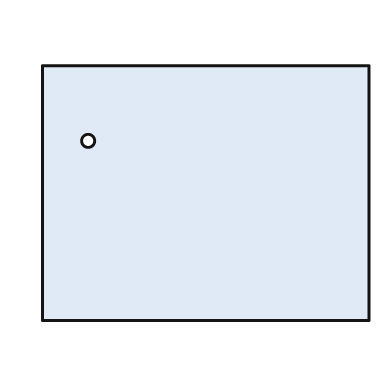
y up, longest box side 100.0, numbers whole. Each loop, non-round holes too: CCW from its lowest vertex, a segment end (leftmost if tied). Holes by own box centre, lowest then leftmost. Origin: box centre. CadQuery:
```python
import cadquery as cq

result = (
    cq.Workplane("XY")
    .moveTo(-50.0, -39.0)
    .lineTo(50.0, -39.0)
    .lineTo(50.0, 39.0)
    .lineTo(-50.0, 39.0)
    .close()
    .moveTo(-36.0, 16.0)
    .circle(2.0)
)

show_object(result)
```